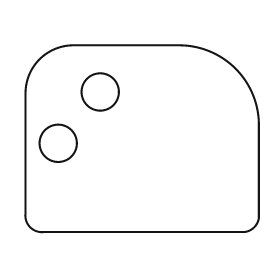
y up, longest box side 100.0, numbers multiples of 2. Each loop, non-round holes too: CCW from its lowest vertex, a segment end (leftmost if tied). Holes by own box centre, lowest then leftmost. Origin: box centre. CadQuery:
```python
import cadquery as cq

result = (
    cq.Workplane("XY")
    .moveTo(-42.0, -40.0)
    .lineTo(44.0, -40.0)
    .threePointArc((48.0, -38.0), (50.0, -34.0))
    .lineTo(50.0, 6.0)
    .threePointArc((40.0, 30.0), (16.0, 40.0))
    .lineTo(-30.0, 40.0)
    .threePointArc((-44.0, 34.0), (-50.0, 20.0))
    .lineTo(-50.0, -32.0)
    .threePointArc((-48.0, -38.0), (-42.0, -40.0))
    .close()
    .moveTo(-36.0, -2.0)
    .circle(8.0)
    .moveTo(-18.0, 20.0)
    .circle(8.0)
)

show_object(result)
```